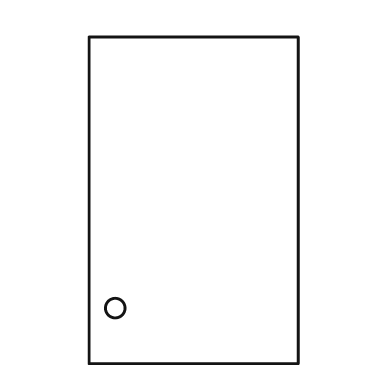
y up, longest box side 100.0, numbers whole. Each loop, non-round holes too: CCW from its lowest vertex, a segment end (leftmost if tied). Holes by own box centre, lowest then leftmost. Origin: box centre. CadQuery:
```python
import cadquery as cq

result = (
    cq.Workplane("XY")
    .moveTo(-32.0, -50.0)
    .lineTo(32.0, -50.0)
    .lineTo(32.0, 50.0)
    .lineTo(-32.0, 50.0)
    .close()
    .moveTo(-24.0, -33.0)
    .circle(3.0)
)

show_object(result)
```